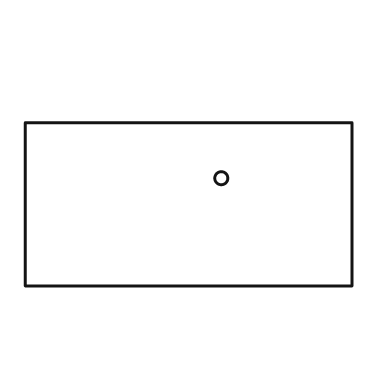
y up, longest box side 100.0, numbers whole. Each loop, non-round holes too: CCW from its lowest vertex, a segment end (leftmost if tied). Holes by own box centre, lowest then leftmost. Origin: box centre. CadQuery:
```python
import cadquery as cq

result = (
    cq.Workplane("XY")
    .moveTo(-50.0, -25.0)
    .lineTo(50.0, -25.0)
    .lineTo(50.0, 25.0)
    .lineTo(-50.0, 25.0)
    .close()
    .moveTo(10.0, 8.0)
    .circle(2.0)
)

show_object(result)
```